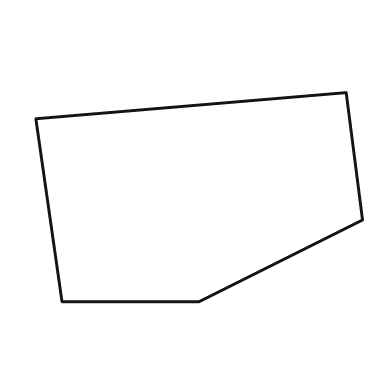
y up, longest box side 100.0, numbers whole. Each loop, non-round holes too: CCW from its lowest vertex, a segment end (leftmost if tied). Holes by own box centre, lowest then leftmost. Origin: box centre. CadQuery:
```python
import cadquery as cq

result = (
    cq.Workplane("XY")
    .moveTo(-42.0, -32.0)
    .lineTo(0.0, -32.0)
    .lineTo(50.0, -7.0)
    .lineTo(45.0, 32.0)
    .lineTo(-50.0, 24.0)
    .close()
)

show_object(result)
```